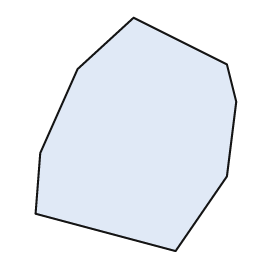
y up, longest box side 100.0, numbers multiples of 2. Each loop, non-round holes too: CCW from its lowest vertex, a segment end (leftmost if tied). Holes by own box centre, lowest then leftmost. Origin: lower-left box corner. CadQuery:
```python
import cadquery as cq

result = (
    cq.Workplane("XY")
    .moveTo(60.0, 0.0)
    .lineTo(82.0, 32.0)
    .lineTo(86.0, 64.0)
    .lineTo(82.0, 80.0)
    .lineTo(42.0, 100.0)
    .lineTo(18.0, 78.0)
    .lineTo(2.0, 42.0)
    .lineTo(0.0, 16.0)
    .close()
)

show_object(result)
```